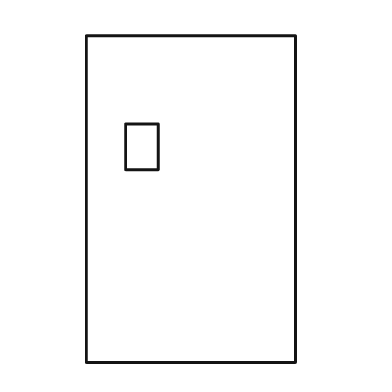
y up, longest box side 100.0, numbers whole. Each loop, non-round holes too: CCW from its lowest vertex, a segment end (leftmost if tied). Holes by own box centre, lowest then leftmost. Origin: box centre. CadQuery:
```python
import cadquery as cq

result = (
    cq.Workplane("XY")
    .moveTo(-32.0, -50.0)
    .lineTo(32.0, -50.0)
    .lineTo(32.0, 50.0)
    .lineTo(-32.0, 50.0)
    .close()
    .moveTo(-20.0, 9.0)
    .lineTo(-10.0, 9.0)
    .lineTo(-10.0, 23.0)
    .lineTo(-20.0, 23.0)
    .close()
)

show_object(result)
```